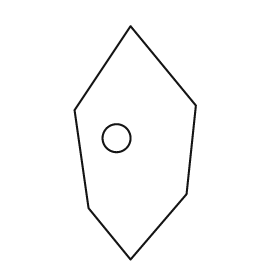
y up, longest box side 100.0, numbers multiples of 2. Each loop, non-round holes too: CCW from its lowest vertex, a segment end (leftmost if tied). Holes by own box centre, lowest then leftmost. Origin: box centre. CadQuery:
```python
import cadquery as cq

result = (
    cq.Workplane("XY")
    .moveTo(-2.0, -50.0)
    .lineTo(22.0, -22.0)
    .lineTo(26.0, 16.0)
    .lineTo(-2.0, 50.0)
    .lineTo(-26.0, 14.0)
    .lineTo(-20.0, -28.0)
    .close()
    .moveTo(-8.0, 2.0)
    .circle(6.0)
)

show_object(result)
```